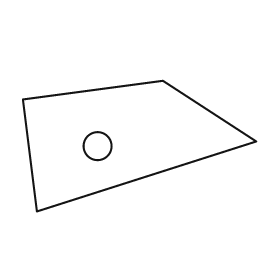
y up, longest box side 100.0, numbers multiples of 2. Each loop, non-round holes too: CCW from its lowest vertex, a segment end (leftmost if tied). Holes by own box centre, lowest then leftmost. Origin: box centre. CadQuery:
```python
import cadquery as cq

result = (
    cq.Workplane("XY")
    .moveTo(-44.0, -28.0)
    .lineTo(50.0, 2.0)
    .lineTo(10.0, 28.0)
    .lineTo(-50.0, 20.0)
    .close()
    .moveTo(-18.0, 0.0)
    .circle(6.0)
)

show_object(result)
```